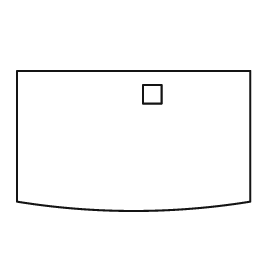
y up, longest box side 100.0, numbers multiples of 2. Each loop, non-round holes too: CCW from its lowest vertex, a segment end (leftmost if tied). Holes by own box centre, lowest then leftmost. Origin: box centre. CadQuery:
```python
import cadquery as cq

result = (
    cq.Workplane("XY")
    .moveTo(-50.0, -26.0)
    .threePointArc((0.0, -30.0), (50.0, -26.0))
    .lineTo(50.0, 30.0)
    .lineTo(-50.0, 30.0)
    .close()
    .moveTo(4.0, 16.0)
    .lineTo(12.0, 16.0)
    .lineTo(12.0, 24.0)
    .lineTo(4.0, 24.0)
    .close()
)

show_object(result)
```